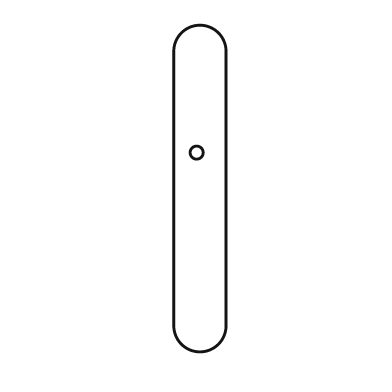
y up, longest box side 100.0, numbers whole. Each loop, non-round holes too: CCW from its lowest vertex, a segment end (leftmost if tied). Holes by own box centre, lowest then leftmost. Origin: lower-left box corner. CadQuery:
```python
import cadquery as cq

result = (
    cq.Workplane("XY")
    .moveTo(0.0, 8.0)
    .threePointArc((8.0, 0.0), (16.0, 8.0))
    .lineTo(16.0, 92.0)
    .threePointArc((8.0, 100.0), (0.0, 92.0))
    .close()
    .moveTo(7.0, 61.0)
    .circle(2.0)
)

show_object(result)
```